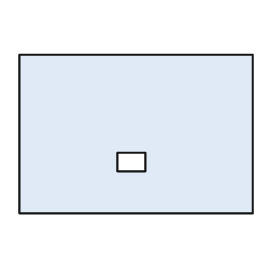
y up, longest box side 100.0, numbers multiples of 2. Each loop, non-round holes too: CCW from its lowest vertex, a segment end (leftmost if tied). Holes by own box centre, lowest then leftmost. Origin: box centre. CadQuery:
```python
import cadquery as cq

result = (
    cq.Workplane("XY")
    .moveTo(-50.0, -34.0)
    .lineTo(50.0, -34.0)
    .lineTo(50.0, 34.0)
    .lineTo(-50.0, 34.0)
    .close()
    .moveTo(-8.0, -16.0)
    .lineTo(4.0, -16.0)
    .lineTo(4.0, -8.0)
    .lineTo(-8.0, -8.0)
    .close()
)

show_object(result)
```